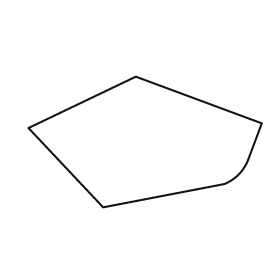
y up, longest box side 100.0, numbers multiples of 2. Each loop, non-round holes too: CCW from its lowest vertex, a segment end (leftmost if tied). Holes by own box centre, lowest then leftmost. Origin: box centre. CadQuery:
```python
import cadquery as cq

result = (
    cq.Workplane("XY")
    .moveTo(-18.0, -28.0)
    .lineTo(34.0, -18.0)
    .threePointArc((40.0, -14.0), (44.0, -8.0))
    .lineTo(50.0, 8.0)
    .lineTo(-4.0, 28.0)
    .lineTo(-50.0, 6.0)
    .close()
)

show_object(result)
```